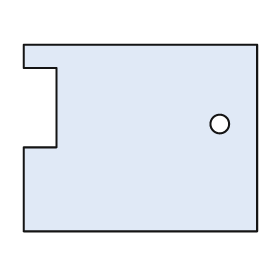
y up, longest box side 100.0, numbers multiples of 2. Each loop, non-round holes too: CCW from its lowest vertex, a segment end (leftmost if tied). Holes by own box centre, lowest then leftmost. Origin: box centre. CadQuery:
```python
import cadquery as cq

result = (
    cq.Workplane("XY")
    .moveTo(-50.0, -40.0)
    .lineTo(50.0, -40.0)
    .lineTo(50.0, 40.0)
    .lineTo(-50.0, 40.0)
    .lineTo(-50.0, 30.0)
    .lineTo(-36.0, 30.0)
    .lineTo(-36.0, -4.0)
    .lineTo(-50.0, -4.0)
    .close()
    .moveTo(34.0, 6.0)
    .circle(4.0)
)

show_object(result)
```